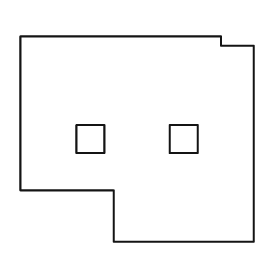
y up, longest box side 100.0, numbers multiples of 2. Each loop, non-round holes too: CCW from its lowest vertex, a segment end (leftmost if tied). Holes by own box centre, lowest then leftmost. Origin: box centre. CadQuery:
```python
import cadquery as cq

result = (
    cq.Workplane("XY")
    .moveTo(-10.0, -44.0)
    .lineTo(50.0, -44.0)
    .lineTo(50.0, 40.0)
    .lineTo(36.0, 40.0)
    .lineTo(36.0, 44.0)
    .lineTo(-50.0, 44.0)
    .lineTo(-50.0, -22.0)
    .lineTo(-10.0, -22.0)
    .close()
    .moveTo(-26.0, -6.0)
    .lineTo(-14.0, -6.0)
    .lineTo(-14.0, 6.0)
    .lineTo(-26.0, 6.0)
    .close()
    .moveTo(14.0, -6.0)
    .lineTo(26.0, -6.0)
    .lineTo(26.0, 6.0)
    .lineTo(14.0, 6.0)
    .close()
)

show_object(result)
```